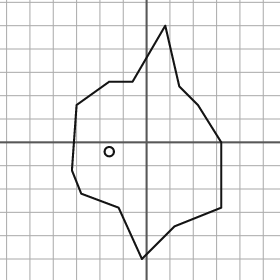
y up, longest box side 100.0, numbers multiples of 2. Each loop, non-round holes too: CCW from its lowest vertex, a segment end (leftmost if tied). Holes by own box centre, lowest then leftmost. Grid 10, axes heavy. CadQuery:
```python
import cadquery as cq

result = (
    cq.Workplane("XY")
    .moveTo(-2.0, -50.0)
    .lineTo(12.0, -36.0)
    .lineTo(32.0, -28.0)
    .lineTo(32.0, 0.0)
    .lineTo(22.0, 16.0)
    .lineTo(14.0, 24.0)
    .lineTo(8.0, 50.0)
    .lineTo(-6.0, 26.0)
    .lineTo(-16.0, 26.0)
    .lineTo(-30.0, 16.0)
    .lineTo(-32.0, -12.0)
    .lineTo(-28.0, -22.0)
    .lineTo(-12.0, -28.0)
    .close()
    .moveTo(-16.0, -4.0)
    .circle(2.0)
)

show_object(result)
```